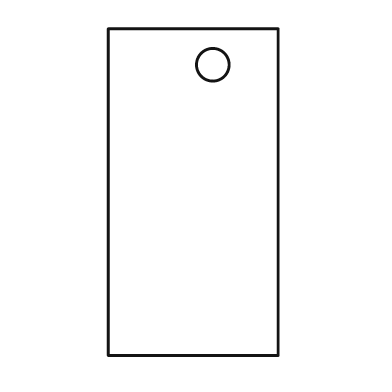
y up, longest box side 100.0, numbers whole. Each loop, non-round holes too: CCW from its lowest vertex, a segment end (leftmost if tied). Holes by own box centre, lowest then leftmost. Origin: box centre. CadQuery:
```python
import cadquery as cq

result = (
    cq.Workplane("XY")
    .moveTo(-26.0, -50.0)
    .lineTo(26.0, -50.0)
    .lineTo(26.0, 50.0)
    .lineTo(-26.0, 50.0)
    .close()
    .moveTo(6.0, 39.0)
    .circle(5.0)
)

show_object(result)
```